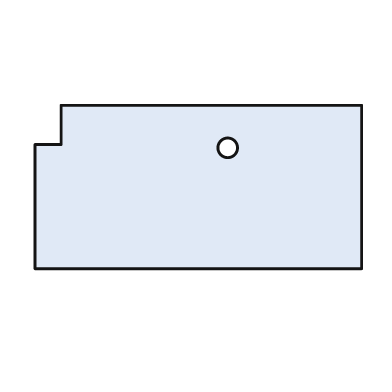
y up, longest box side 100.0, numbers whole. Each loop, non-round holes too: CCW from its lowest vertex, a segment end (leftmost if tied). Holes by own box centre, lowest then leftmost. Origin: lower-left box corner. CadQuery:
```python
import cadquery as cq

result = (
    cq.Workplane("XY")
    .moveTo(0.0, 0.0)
    .lineTo(100.0, 0.0)
    .lineTo(100.0, 50.0)
    .lineTo(8.0, 50.0)
    .lineTo(8.0, 38.0)
    .lineTo(0.0, 38.0)
    .close()
    .moveTo(59.0, 37.0)
    .circle(3.0)
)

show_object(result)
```